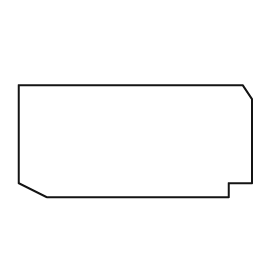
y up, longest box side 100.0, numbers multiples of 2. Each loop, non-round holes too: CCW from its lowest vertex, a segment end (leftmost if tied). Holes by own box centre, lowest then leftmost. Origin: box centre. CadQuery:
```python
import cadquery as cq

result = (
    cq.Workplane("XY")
    .moveTo(-38.0, -24.0)
    .lineTo(40.0, -24.0)
    .lineTo(40.0, -18.0)
    .lineTo(50.0, -18.0)
    .lineTo(50.0, 18.0)
    .lineTo(46.0, 24.0)
    .lineTo(-50.0, 24.0)
    .lineTo(-50.0, -18.0)
    .close()
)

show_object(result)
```